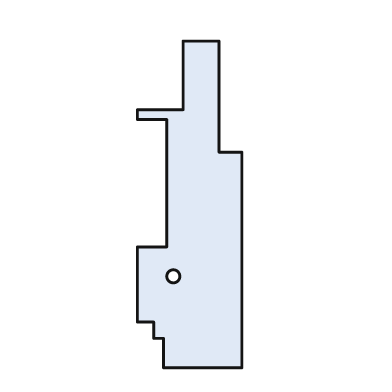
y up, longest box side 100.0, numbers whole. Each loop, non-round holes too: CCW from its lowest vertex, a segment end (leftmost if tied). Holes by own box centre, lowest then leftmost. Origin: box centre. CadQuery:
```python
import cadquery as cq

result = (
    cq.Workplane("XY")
    .moveTo(-8.0, -50.0)
    .lineTo(16.0, -50.0)
    .lineTo(16.0, 16.0)
    .lineTo(9.0, 16.0)
    .lineTo(9.0, 50.0)
    .lineTo(-2.0, 50.0)
    .lineTo(-2.0, 29.0)
    .lineTo(-16.0, 29.0)
    .lineTo(-16.0, 26.0)
    .lineTo(-7.0, 26.0)
    .lineTo(-7.0, -13.0)
    .lineTo(-16.0, -13.0)
    .lineTo(-16.0, -36.0)
    .lineTo(-11.0, -36.0)
    .lineTo(-11.0, -41.0)
    .lineTo(-8.0, -41.0)
    .close()
    .moveTo(-5.0, -22.0)
    .circle(2.0)
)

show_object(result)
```